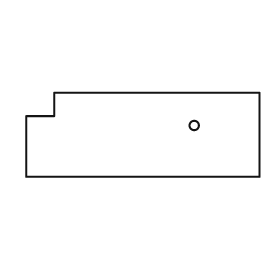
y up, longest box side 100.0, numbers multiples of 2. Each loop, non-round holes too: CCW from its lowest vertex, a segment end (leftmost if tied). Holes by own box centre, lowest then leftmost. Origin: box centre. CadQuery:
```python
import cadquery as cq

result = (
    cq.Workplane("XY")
    .moveTo(-50.0, -18.0)
    .lineTo(50.0, -18.0)
    .lineTo(50.0, 18.0)
    .lineTo(-38.0, 18.0)
    .lineTo(-38.0, 8.0)
    .lineTo(-50.0, 8.0)
    .close()
    .moveTo(22.0, 4.0)
    .circle(2.0)
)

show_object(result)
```